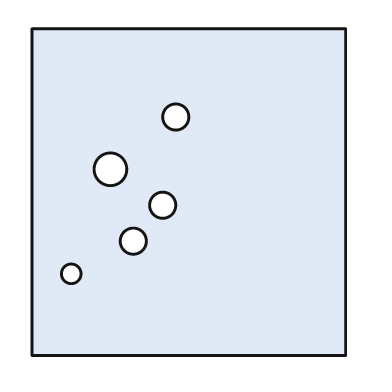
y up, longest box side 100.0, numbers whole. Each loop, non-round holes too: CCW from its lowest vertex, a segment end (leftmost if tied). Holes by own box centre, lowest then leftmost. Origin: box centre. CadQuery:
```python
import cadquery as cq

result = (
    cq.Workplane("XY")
    .moveTo(-48.0, -50.0)
    .lineTo(48.0, -50.0)
    .lineTo(48.0, 50.0)
    .lineTo(-48.0, 50.0)
    .close()
    .moveTo(-36.0, -25.0)
    .circle(3.0)
    .moveTo(-17.0, -15.0)
    .circle(4.0)
    .moveTo(-8.0, -4.0)
    .circle(4.0)
    .moveTo(-24.0, 7.0)
    .circle(5.0)
    .moveTo(-4.0, 23.0)
    .circle(4.0)
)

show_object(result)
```